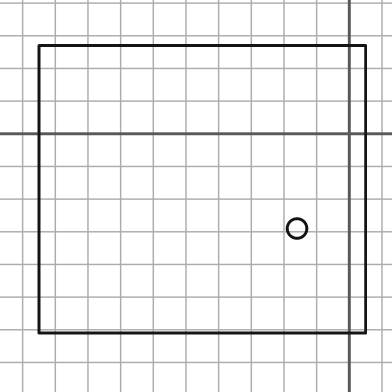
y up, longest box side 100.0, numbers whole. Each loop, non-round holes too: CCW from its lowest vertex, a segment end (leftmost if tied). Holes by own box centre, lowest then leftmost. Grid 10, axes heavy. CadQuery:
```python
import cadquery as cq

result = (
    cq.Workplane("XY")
    .moveTo(-95.0, -61.0)
    .lineTo(5.0, -61.0)
    .lineTo(5.0, 27.0)
    .lineTo(-95.0, 27.0)
    .close()
    .moveTo(-16.0, -29.0)
    .circle(3.0)
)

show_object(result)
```